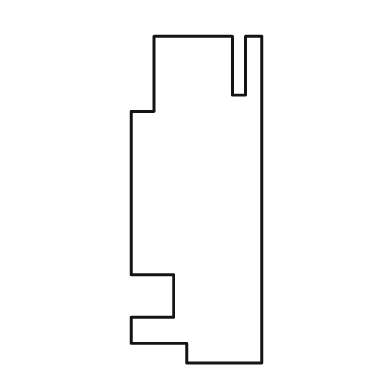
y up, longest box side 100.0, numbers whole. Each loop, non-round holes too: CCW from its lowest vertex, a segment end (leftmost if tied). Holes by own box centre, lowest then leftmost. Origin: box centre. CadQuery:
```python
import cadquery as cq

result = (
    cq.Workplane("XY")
    .moveTo(-3.0, -50.0)
    .lineTo(20.0, -50.0)
    .lineTo(20.0, 50.0)
    .lineTo(15.0, 50.0)
    .lineTo(15.0, 32.0)
    .lineTo(11.0, 32.0)
    .lineTo(11.0, 50.0)
    .lineTo(-13.0, 50.0)
    .lineTo(-13.0, 27.0)
    .lineTo(-20.0, 27.0)
    .lineTo(-20.0, -23.0)
    .lineTo(-7.0, -23.0)
    .lineTo(-7.0, -36.0)
    .lineTo(-20.0, -36.0)
    .lineTo(-20.0, -44.0)
    .lineTo(-3.0, -44.0)
    .close()
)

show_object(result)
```